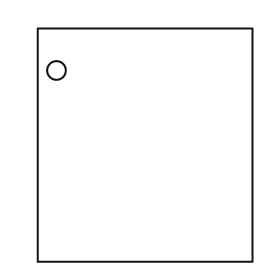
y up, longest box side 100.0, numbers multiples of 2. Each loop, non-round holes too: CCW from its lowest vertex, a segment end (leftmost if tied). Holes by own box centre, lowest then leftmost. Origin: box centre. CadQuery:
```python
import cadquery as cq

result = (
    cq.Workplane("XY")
    .moveTo(-46.0, -50.0)
    .lineTo(46.0, -50.0)
    .lineTo(46.0, 50.0)
    .lineTo(-46.0, 50.0)
    .close()
    .moveTo(-38.0, 32.0)
    .circle(4.0)
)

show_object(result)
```